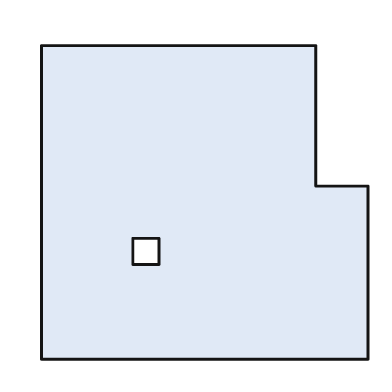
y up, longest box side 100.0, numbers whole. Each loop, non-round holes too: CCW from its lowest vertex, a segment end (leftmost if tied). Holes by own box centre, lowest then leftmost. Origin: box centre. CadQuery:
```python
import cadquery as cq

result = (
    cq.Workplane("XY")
    .moveTo(-50.0, -48.0)
    .lineTo(50.0, -48.0)
    .lineTo(50.0, 5.0)
    .lineTo(34.0, 5.0)
    .lineTo(34.0, 48.0)
    .lineTo(-50.0, 48.0)
    .close()
    .moveTo(-22.0, -19.0)
    .lineTo(-14.0, -19.0)
    .lineTo(-14.0, -11.0)
    .lineTo(-22.0, -11.0)
    .close()
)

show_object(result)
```